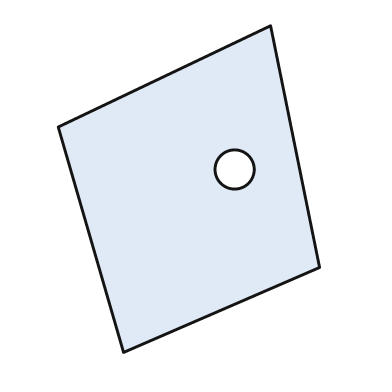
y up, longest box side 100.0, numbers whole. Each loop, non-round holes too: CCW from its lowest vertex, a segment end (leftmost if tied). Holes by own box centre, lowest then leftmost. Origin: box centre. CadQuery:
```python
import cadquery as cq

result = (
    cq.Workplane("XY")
    .moveTo(-20.0, -50.0)
    .lineTo(40.0, -24.0)
    .lineTo(25.0, 50.0)
    .lineTo(-40.0, 19.0)
    .close()
    .moveTo(14.0, 6.0)
    .circle(6.0)
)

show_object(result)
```